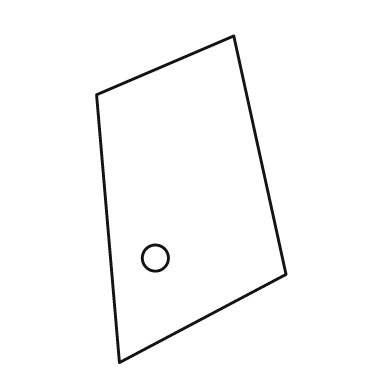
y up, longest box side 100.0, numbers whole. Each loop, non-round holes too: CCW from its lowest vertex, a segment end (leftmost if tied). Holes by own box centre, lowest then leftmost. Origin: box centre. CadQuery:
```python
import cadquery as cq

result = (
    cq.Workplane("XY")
    .moveTo(-22.0, -50.0)
    .lineTo(29.0, -23.0)
    .lineTo(13.0, 50.0)
    .lineTo(-29.0, 32.0)
    .close()
    .moveTo(-11.0, -18.0)
    .circle(4.0)
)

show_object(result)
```